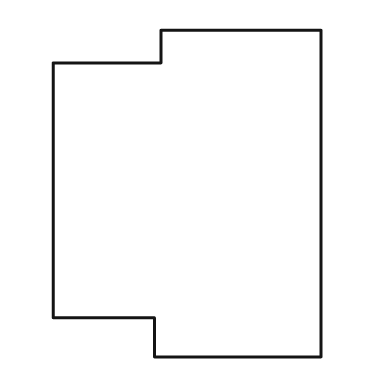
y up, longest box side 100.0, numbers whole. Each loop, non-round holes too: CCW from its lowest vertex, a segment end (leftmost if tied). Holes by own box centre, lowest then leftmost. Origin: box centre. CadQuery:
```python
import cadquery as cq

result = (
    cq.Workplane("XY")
    .moveTo(-10.0, -50.0)
    .lineTo(41.0, -50.0)
    .lineTo(41.0, 50.0)
    .lineTo(-8.0, 50.0)
    .lineTo(-8.0, 40.0)
    .lineTo(-41.0, 40.0)
    .lineTo(-41.0, -38.0)
    .lineTo(-10.0, -38.0)
    .close()
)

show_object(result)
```